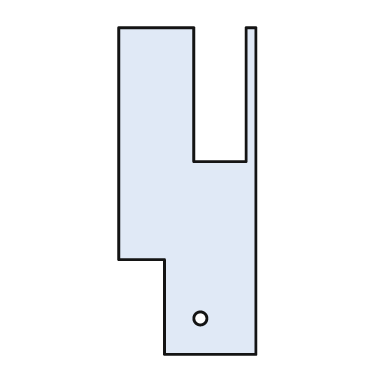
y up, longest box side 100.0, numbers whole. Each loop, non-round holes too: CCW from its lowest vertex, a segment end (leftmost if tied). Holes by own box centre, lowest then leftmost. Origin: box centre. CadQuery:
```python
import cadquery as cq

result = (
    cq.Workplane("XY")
    .moveTo(-7.0, -50.0)
    .lineTo(21.0, -50.0)
    .lineTo(21.0, 50.0)
    .lineTo(18.0, 50.0)
    .lineTo(18.0, 9.0)
    .lineTo(2.0, 9.0)
    .lineTo(2.0, 50.0)
    .lineTo(-21.0, 50.0)
    .lineTo(-21.0, -21.0)
    .lineTo(-7.0, -21.0)
    .close()
    .moveTo(4.0, -39.0)
    .circle(2.0)
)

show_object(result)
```